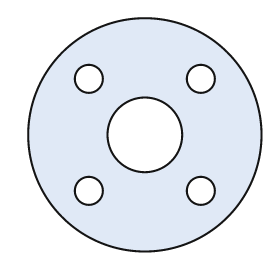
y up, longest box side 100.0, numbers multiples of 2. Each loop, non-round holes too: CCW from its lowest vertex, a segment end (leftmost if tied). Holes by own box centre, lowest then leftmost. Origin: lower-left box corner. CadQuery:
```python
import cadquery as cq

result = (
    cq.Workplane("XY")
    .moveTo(50.0, 50.0)
    .circle(50.0)
    .moveTo(26.0, 26.0)
    .circle(6.0)
    .moveTo(74.0, 26.0)
    .circle(6.0)
    .moveTo(50.0, 50.0)
    .circle(16.0)
    .moveTo(26.0, 74.0)
    .circle(6.0)
    .moveTo(74.0, 74.0)
    .circle(6.0)
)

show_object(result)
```